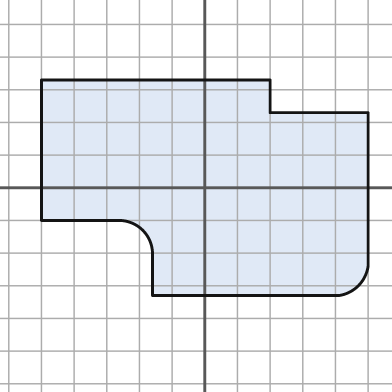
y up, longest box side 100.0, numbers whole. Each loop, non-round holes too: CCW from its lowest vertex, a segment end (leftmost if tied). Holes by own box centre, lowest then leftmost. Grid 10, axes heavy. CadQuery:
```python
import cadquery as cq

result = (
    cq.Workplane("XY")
    .moveTo(-16.0, -33.0)
    .lineTo(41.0, -33.0)
    .threePointArc((47.0, -30.0), (50.0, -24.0))
    .lineTo(50.0, 23.0)
    .lineTo(20.0, 23.0)
    .lineTo(20.0, 33.0)
    .lineTo(-50.0, 33.0)
    .lineTo(-50.0, -10.0)
    .lineTo(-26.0, -10.0)
    .threePointArc((-19.0, -13.0), (-16.0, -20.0))
    .close()
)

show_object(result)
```